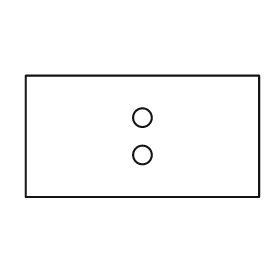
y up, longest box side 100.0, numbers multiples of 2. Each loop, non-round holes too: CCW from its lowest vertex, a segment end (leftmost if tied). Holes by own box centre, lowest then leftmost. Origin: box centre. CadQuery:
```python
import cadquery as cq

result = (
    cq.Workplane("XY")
    .moveTo(-50.0, -26.0)
    .lineTo(50.0, -26.0)
    .lineTo(50.0, 26.0)
    .lineTo(-50.0, 26.0)
    .close()
    .moveTo(0.0, -8.0)
    .circle(4.0)
    .moveTo(0.0, 8.0)
    .circle(4.0)
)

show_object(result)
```